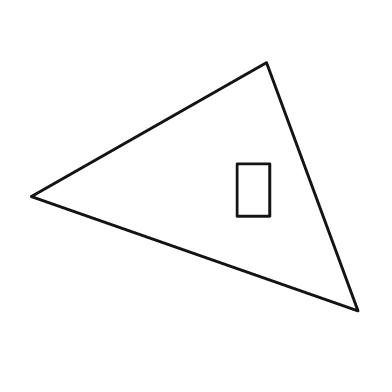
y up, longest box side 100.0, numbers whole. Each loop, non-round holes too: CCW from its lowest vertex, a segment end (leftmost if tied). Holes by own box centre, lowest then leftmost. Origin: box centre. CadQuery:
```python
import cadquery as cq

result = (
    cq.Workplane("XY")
    .moveTo(50.0, -38.0)
    .lineTo(22.0, 38.0)
    .lineTo(-50.0, -3.0)
    .close()
    .moveTo(13.0, -9.0)
    .lineTo(23.0, -9.0)
    .lineTo(23.0, 7.0)
    .lineTo(13.0, 7.0)
    .close()
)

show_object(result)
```